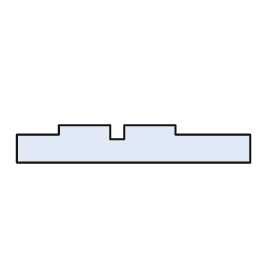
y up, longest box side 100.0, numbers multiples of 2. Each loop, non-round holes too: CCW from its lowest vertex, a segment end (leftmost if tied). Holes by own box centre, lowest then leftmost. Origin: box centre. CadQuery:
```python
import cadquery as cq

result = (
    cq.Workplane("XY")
    .moveTo(-50.0, -8.0)
    .lineTo(50.0, -8.0)
    .lineTo(50.0, 4.0)
    .lineTo(18.0, 4.0)
    .lineTo(18.0, 8.0)
    .lineTo(-4.0, 8.0)
    .lineTo(-4.0, 2.0)
    .lineTo(-10.0, 2.0)
    .lineTo(-10.0, 8.0)
    .lineTo(-32.0, 8.0)
    .lineTo(-32.0, 4.0)
    .lineTo(-50.0, 4.0)
    .close()
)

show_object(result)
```